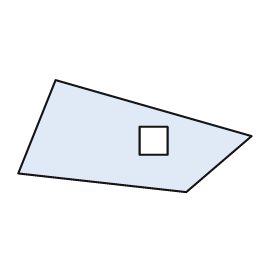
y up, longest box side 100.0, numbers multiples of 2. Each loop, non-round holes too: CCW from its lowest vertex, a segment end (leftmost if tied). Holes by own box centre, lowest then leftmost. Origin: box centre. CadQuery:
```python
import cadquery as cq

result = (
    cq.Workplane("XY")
    .moveTo(22.0, -24.0)
    .lineTo(50.0, 0.0)
    .lineTo(-34.0, 24.0)
    .lineTo(-50.0, -16.0)
    .close()
    .moveTo(2.0, -8.0)
    .lineTo(14.0, -8.0)
    .lineTo(14.0, 4.0)
    .lineTo(2.0, 4.0)
    .close()
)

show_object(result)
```